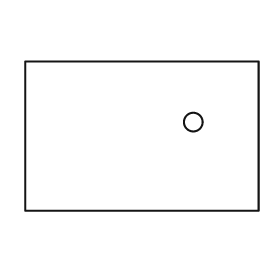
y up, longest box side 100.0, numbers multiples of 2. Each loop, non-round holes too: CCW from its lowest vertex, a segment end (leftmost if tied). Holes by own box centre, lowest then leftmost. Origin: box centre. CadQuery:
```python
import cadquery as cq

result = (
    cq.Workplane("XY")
    .moveTo(-50.0, -32.0)
    .lineTo(50.0, -32.0)
    .lineTo(50.0, 32.0)
    .lineTo(-50.0, 32.0)
    .close()
    .moveTo(22.0, 6.0)
    .circle(4.0)
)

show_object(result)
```